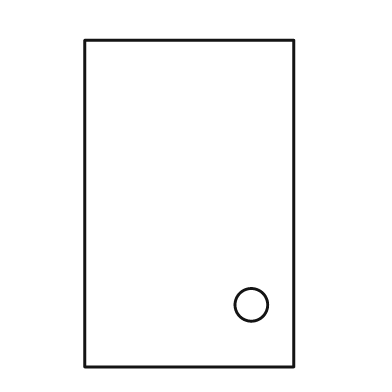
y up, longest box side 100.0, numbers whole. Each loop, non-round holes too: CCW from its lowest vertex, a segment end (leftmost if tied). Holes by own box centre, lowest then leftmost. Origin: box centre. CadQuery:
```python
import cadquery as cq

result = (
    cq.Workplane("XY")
    .moveTo(-32.0, -50.0)
    .lineTo(32.0, -50.0)
    .lineTo(32.0, 50.0)
    .lineTo(-32.0, 50.0)
    .close()
    .moveTo(19.0, -31.0)
    .circle(5.0)
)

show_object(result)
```